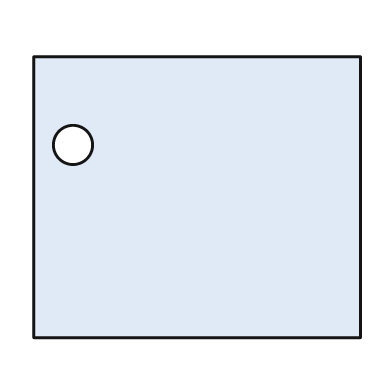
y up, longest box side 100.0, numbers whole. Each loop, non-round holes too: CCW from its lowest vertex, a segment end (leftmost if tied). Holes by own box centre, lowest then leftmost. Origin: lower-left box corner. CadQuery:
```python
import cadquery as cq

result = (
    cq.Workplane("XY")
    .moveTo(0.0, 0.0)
    .lineTo(100.0, 0.0)
    .lineTo(100.0, 86.0)
    .lineTo(0.0, 86.0)
    .close()
    .moveTo(12.0, 59.0)
    .circle(6.0)
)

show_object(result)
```